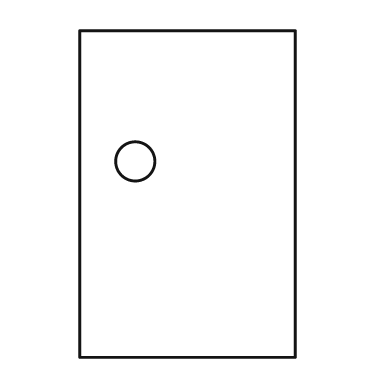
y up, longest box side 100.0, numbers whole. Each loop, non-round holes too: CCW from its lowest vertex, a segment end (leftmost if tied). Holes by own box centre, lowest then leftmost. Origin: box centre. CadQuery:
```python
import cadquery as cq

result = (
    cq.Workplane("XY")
    .moveTo(-33.0, -50.0)
    .lineTo(33.0, -50.0)
    .lineTo(33.0, 50.0)
    .lineTo(-33.0, 50.0)
    .close()
    .moveTo(-16.0, 10.0)
    .circle(6.0)
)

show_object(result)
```